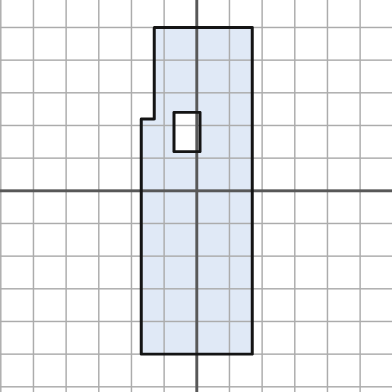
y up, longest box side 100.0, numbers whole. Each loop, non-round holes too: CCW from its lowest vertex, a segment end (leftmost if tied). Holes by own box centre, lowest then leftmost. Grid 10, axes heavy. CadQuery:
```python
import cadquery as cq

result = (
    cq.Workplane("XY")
    .moveTo(-17.0, -50.0)
    .lineTo(17.0, -50.0)
    .lineTo(17.0, 50.0)
    .lineTo(-13.0, 50.0)
    .lineTo(-13.0, 22.0)
    .lineTo(-17.0, 22.0)
    .close()
    .moveTo(-7.0, 12.0)
    .lineTo(1.0, 12.0)
    .lineTo(1.0, 24.0)
    .lineTo(-7.0, 24.0)
    .close()
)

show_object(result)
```